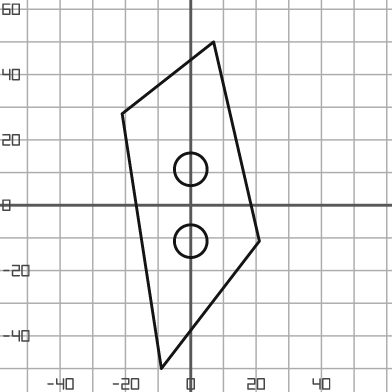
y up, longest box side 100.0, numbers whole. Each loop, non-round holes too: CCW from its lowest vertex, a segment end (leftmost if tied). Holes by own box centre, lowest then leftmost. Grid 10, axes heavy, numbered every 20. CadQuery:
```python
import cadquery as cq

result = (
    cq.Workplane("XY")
    .moveTo(-9.0, -50.0)
    .lineTo(21.0, -11.0)
    .lineTo(7.0, 50.0)
    .lineTo(-21.0, 28.0)
    .close()
    .moveTo(0.0, -11.0)
    .circle(5.0)
    .moveTo(0.0, 11.0)
    .circle(5.0)
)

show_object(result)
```